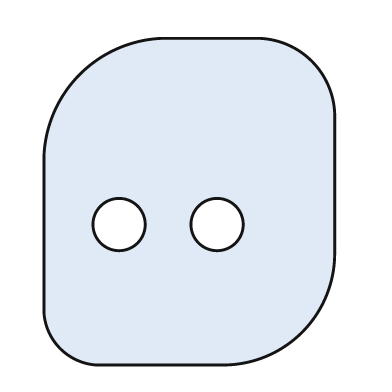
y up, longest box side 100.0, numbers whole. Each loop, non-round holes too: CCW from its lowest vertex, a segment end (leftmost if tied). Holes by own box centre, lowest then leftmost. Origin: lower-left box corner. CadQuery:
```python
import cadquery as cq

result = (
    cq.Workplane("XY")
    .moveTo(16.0, 0.0)
    .lineTo(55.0, 0.0)
    .threePointArc((79.0, 10.0), (89.0, 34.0))
    .lineTo(89.0, 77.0)
    .threePointArc((82.0, 93.0), (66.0, 100.0))
    .lineTo(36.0, 100.0)
    .threePointArc((11.0, 89.0), (0.0, 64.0))
    .lineTo(0.0, 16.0)
    .threePointArc((5.0, 5.0), (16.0, 0.0))
    .close()
    .moveTo(23.0, 43.0)
    .circle(8.0)
    .moveTo(53.0, 43.0)
    .circle(8.0)
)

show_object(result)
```